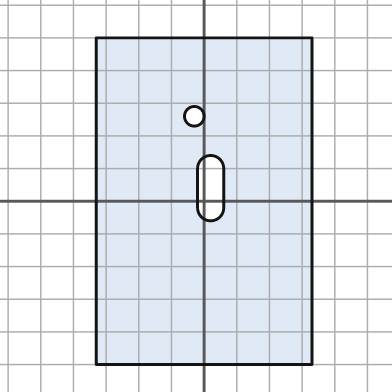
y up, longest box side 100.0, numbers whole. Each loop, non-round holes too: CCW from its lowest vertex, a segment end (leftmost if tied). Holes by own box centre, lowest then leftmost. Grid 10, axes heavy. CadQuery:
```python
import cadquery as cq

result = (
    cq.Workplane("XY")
    .moveTo(-33.0, -50.0)
    .lineTo(33.0, -50.0)
    .lineTo(33.0, 50.0)
    .lineTo(-33.0, 50.0)
    .close()
    .moveTo(-2.0, -2.0)
    .threePointArc((2.0, -6.0), (6.0, -2.0))
    .lineTo(6.0, 10.0)
    .threePointArc((2.0, 14.0), (-2.0, 10.0))
    .close()
    .moveTo(-3.0, 26.0)
    .circle(3.0)
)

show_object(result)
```